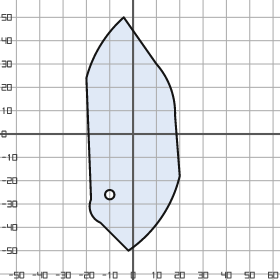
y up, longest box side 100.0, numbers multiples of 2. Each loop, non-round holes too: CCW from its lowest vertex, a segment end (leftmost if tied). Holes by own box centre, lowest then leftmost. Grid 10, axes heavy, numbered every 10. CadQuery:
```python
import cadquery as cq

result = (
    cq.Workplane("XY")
    .moveTo(-2.0, -50.0)
    .threePointArc((12.0, -36.0), (20.0, -18.0))
    .lineTo(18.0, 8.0)
    .threePointArc((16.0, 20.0), (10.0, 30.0))
    .lineTo(-4.0, 50.0)
    .threePointArc((-14.0, 38.0), (-20.0, 24.0))
    .lineTo(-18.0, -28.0)
    .threePointArc((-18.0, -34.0), (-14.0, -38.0))
    .close()
    .moveTo(-10.0, -26.0)
    .circle(2.0)
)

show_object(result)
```